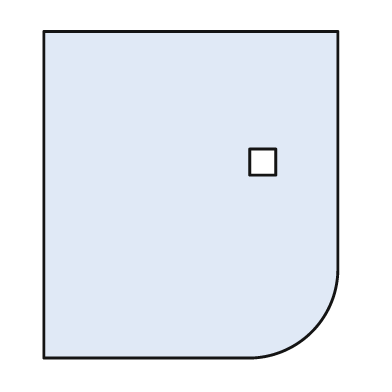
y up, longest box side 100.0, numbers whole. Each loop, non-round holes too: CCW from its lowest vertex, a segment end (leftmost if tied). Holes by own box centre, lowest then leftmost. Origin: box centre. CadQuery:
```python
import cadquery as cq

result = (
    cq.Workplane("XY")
    .moveTo(-45.0, -50.0)
    .lineTo(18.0, -50.0)
    .threePointArc((37.0, -42.0), (45.0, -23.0))
    .lineTo(45.0, 50.0)
    .lineTo(-45.0, 50.0)
    .close()
    .moveTo(18.0, 6.0)
    .lineTo(26.0, 6.0)
    .lineTo(26.0, 14.0)
    .lineTo(18.0, 14.0)
    .close()
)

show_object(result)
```